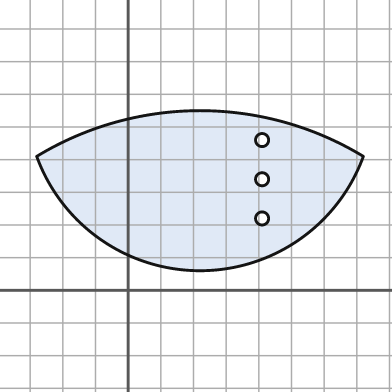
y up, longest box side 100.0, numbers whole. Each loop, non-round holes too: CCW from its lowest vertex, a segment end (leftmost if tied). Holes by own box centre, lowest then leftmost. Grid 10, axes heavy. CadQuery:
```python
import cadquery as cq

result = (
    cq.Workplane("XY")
    .moveTo(-28.0, 41.0)
    .threePointArc((22.0, 6.0), (72.0, 41.0))
    .threePointArc((22.0, 55.0), (-28.0, 41.0))
    .close()
    .moveTo(41.0, 22.0)
    .circle(2.0)
    .moveTo(41.0, 34.0)
    .circle(2.0)
    .moveTo(41.0, 46.0)
    .circle(2.0)
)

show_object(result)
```